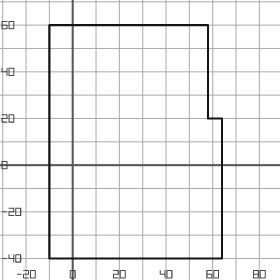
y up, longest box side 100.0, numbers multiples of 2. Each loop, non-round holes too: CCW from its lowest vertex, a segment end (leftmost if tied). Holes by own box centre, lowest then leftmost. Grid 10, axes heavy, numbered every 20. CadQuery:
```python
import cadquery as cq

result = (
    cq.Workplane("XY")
    .moveTo(-10.0, -40.0)
    .lineTo(64.0, -40.0)
    .lineTo(64.0, 20.0)
    .lineTo(58.0, 20.0)
    .lineTo(58.0, 60.0)
    .lineTo(-10.0, 60.0)
    .close()
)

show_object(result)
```